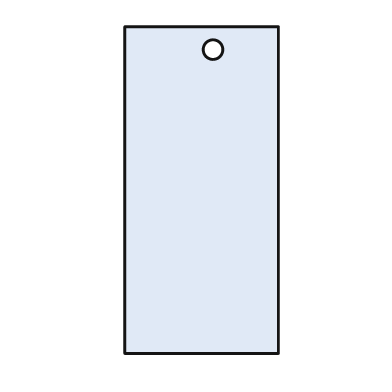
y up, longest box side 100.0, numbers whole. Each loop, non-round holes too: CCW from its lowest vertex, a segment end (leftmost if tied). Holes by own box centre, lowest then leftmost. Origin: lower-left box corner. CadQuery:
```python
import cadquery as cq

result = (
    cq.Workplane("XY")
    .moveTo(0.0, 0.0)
    .lineTo(47.0, 0.0)
    .lineTo(47.0, 100.0)
    .lineTo(0.0, 100.0)
    .close()
    .moveTo(27.0, 93.0)
    .circle(3.0)
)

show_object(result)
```